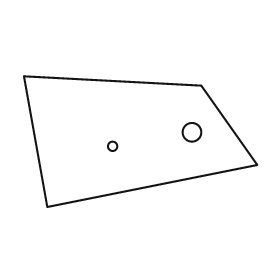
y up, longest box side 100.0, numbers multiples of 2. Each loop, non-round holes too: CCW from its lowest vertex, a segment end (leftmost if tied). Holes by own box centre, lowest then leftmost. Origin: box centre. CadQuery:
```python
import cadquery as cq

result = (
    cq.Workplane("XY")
    .moveTo(-40.0, -28.0)
    .lineTo(50.0, -10.0)
    .lineTo(26.0, 24.0)
    .lineTo(-50.0, 28.0)
    .close()
    .moveTo(-12.0, -2.0)
    .circle(2.0)
    .moveTo(22.0, 4.0)
    .circle(4.0)
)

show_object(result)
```